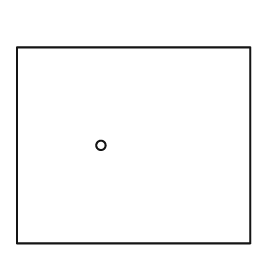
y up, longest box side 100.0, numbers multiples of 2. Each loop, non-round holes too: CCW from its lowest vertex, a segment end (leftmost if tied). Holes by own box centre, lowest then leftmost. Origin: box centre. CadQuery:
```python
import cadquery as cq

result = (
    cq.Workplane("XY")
    .moveTo(-50.0, -42.0)
    .lineTo(50.0, -42.0)
    .lineTo(50.0, 42.0)
    .lineTo(-50.0, 42.0)
    .close()
    .moveTo(-14.0, 0.0)
    .circle(2.0)
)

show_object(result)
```